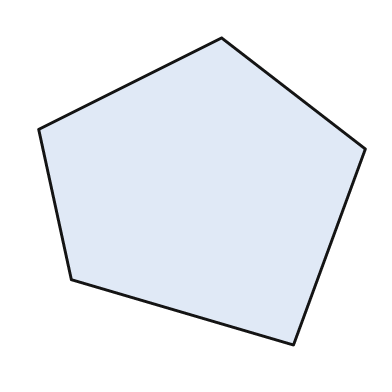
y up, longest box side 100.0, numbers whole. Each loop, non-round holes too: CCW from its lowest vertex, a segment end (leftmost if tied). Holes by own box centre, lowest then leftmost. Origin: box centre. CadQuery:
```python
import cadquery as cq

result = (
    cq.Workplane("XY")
    .moveTo(28.0, -47.0)
    .lineTo(50.0, 13.0)
    .lineTo(6.0, 47.0)
    .lineTo(-50.0, 19.0)
    .lineTo(-40.0, -27.0)
    .close()
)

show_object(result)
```